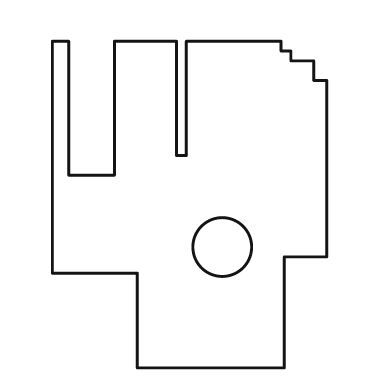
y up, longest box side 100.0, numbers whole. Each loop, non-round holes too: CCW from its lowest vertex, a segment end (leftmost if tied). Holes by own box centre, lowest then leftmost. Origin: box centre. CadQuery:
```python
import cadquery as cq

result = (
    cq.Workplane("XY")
    .moveTo(-16.0, -50.0)
    .lineTo(29.0, -50.0)
    .lineTo(29.0, -16.0)
    .lineTo(42.0, -16.0)
    .lineTo(42.0, 38.0)
    .lineTo(38.0, 38.0)
    .lineTo(38.0, 44.0)
    .lineTo(31.0, 44.0)
    .lineTo(31.0, 47.0)
    .lineTo(28.0, 47.0)
    .lineTo(28.0, 50.0)
    .lineTo(-1.0, 50.0)
    .lineTo(-1.0, 15.0)
    .lineTo(-4.0, 15.0)
    .lineTo(-4.0, 50.0)
    .lineTo(-23.0, 50.0)
    .lineTo(-23.0, 9.0)
    .lineTo(-37.0, 9.0)
    .lineTo(-37.0, 50.0)
    .lineTo(-42.0, 50.0)
    .lineTo(-42.0, -21.0)
    .lineTo(-16.0, -21.0)
    .close()
    .moveTo(10.0, -13.0)
    .circle(9.0)
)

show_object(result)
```